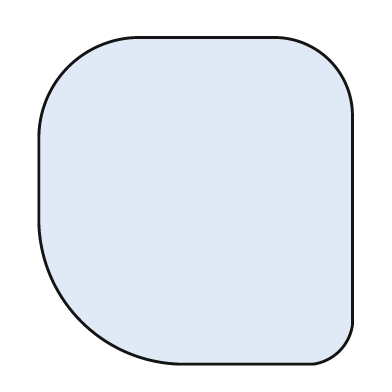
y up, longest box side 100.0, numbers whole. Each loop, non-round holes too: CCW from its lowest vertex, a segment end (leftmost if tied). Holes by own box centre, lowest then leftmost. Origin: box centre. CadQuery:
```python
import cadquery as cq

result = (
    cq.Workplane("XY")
    .moveTo(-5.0, -50.0)
    .lineTo(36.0, -50.0)
    .threePointArc((44.0, -46.0), (48.0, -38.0))
    .lineTo(48.0, 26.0)
    .threePointArc((41.0, 43.0), (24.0, 50.0))
    .lineTo(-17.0, 50.0)
    .threePointArc((-39.0, 41.0), (-48.0, 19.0))
    .lineTo(-48.0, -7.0)
    .threePointArc((-35.0, -37.0), (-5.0, -50.0))
    .close()
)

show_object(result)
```